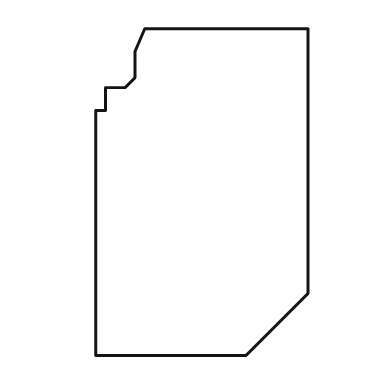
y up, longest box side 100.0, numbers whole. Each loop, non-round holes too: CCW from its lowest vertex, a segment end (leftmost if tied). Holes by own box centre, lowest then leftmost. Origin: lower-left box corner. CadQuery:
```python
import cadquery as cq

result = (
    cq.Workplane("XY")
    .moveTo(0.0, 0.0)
    .lineTo(46.0, 0.0)
    .lineTo(65.0, 19.0)
    .lineTo(65.0, 100.0)
    .lineTo(15.0, 100.0)
    .lineTo(12.0, 93.0)
    .lineTo(12.0, 85.0)
    .lineTo(9.0, 82.0)
    .lineTo(3.0, 82.0)
    .lineTo(3.0, 75.0)
    .lineTo(0.0, 75.0)
    .close()
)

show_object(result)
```